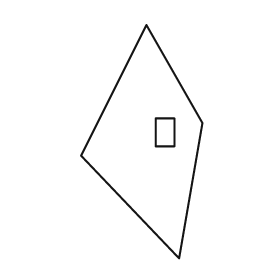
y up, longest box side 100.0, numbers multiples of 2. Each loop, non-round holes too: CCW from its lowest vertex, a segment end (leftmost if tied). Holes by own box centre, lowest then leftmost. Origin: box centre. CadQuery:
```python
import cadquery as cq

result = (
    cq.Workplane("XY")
    .moveTo(16.0, -50.0)
    .lineTo(26.0, 8.0)
    .lineTo(2.0, 50.0)
    .lineTo(-26.0, -6.0)
    .close()
    .moveTo(6.0, -2.0)
    .lineTo(14.0, -2.0)
    .lineTo(14.0, 10.0)
    .lineTo(6.0, 10.0)
    .close()
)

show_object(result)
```